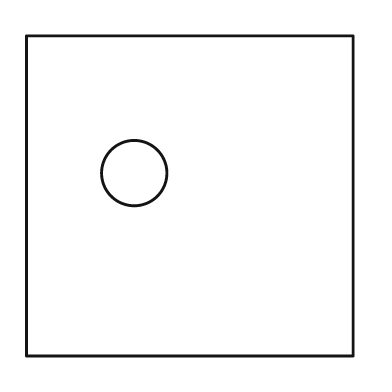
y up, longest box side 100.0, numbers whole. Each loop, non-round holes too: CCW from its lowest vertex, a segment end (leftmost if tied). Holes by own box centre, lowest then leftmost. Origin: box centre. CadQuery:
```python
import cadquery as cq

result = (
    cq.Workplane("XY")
    .moveTo(-50.0, -49.0)
    .lineTo(50.0, -49.0)
    .lineTo(50.0, 49.0)
    .lineTo(-50.0, 49.0)
    .close()
    .moveTo(-17.0, 7.0)
    .circle(10.0)
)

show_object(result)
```